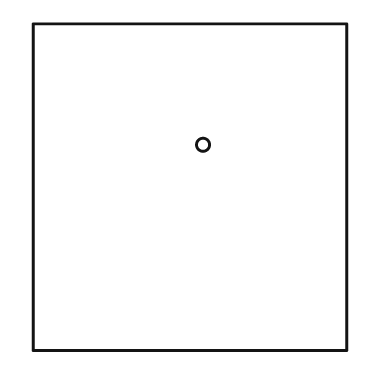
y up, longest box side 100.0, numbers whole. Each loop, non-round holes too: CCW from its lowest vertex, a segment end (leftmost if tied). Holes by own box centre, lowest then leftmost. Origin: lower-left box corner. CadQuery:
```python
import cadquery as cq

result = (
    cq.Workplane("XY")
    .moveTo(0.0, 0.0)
    .lineTo(96.0, 0.0)
    .lineTo(96.0, 100.0)
    .lineTo(0.0, 100.0)
    .close()
    .moveTo(52.0, 63.0)
    .circle(2.0)
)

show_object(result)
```